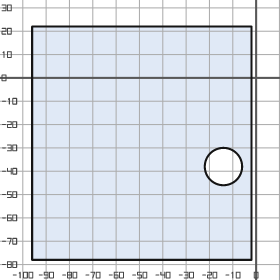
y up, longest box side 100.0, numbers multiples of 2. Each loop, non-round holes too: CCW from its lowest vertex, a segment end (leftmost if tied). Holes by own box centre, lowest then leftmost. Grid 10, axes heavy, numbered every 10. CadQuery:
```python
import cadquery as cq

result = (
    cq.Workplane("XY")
    .moveTo(-96.0, -78.0)
    .lineTo(-2.0, -78.0)
    .lineTo(-2.0, 22.0)
    .lineTo(-96.0, 22.0)
    .close()
    .moveTo(-14.0, -38.0)
    .circle(8.0)
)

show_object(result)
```